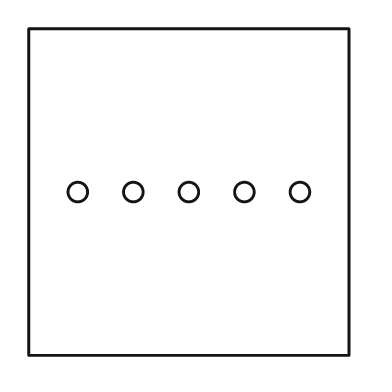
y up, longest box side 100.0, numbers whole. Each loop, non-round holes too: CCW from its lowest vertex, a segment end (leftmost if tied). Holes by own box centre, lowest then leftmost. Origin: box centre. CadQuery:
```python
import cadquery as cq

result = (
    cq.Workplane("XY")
    .moveTo(-49.0, -50.0)
    .lineTo(49.0, -50.0)
    .lineTo(49.0, 50.0)
    .lineTo(-49.0, 50.0)
    .close()
    .moveTo(-34.0, 0.0)
    .circle(3.0)
    .moveTo(-17.0, 0.0)
    .circle(3.0)
    .moveTo(0.0, 0.0)
    .circle(3.0)
    .moveTo(17.0, 0.0)
    .circle(3.0)
    .moveTo(34.0, 0.0)
    .circle(3.0)
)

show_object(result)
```